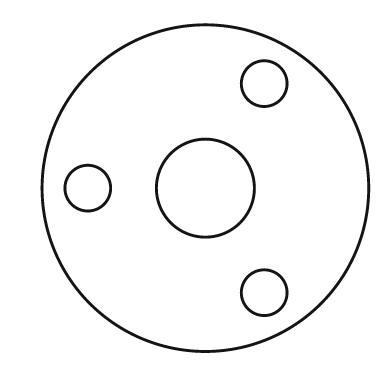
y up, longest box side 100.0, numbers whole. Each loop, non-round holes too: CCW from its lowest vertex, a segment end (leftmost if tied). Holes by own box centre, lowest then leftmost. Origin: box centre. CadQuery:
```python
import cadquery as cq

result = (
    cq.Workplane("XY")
    .moveTo(0.0, 0.0)
    .circle(50.0)
    .moveTo(18.0, -32.0)
    .circle(7.0)
    .moveTo(-36.0, 0.0)
    .circle(7.0)
    .moveTo(0.0, 0.0)
    .circle(15.0)
    .moveTo(18.0, 32.0)
    .circle(7.0)
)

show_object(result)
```